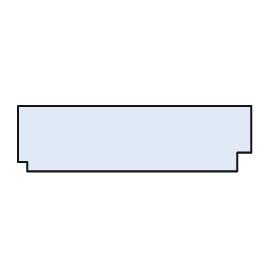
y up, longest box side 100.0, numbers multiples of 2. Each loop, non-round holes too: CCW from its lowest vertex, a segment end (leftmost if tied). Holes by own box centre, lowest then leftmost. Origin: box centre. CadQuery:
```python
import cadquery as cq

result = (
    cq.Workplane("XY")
    .moveTo(-46.0, -14.0)
    .lineTo(44.0, -14.0)
    .lineTo(44.0, -6.0)
    .lineTo(50.0, -6.0)
    .lineTo(50.0, 14.0)
    .lineTo(-50.0, 14.0)
    .lineTo(-50.0, -10.0)
    .lineTo(-46.0, -10.0)
    .close()
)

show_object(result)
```